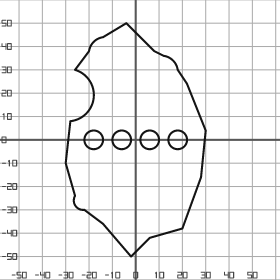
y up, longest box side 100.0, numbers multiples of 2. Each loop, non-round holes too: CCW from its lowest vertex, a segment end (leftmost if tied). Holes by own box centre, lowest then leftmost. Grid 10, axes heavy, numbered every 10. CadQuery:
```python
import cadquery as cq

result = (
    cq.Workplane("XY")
    .moveTo(-2.0, -50.0)
    .lineTo(6.0, -42.0)
    .lineTo(20.0, -38.0)
    .lineTo(28.0, -16.0)
    .lineTo(30.0, 4.0)
    .lineTo(22.0, 24.0)
    .lineTo(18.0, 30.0)
    .threePointArc((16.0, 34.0), (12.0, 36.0))
    .lineTo(8.0, 38.0)
    .lineTo(-4.0, 50.0)
    .lineTo(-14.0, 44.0)
    .threePointArc((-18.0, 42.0), (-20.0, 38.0))
    .lineTo(-26.0, 30.0)
    .threePointArc((-18.0, 18.0), (-28.0, 8.0))
    .lineTo(-30.0, -10.0)
    .lineTo(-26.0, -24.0)
    .threePointArc((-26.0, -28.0), (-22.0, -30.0))
    .lineTo(-14.0, -36.0)
    .close()
    .moveTo(-18.0, 0.0)
    .circle(4.0)
    .moveTo(-6.0, 0.0)
    .circle(4.0)
    .moveTo(6.0, 0.0)
    .circle(4.0)
    .moveTo(18.0, 0.0)
    .circle(4.0)
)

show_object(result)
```